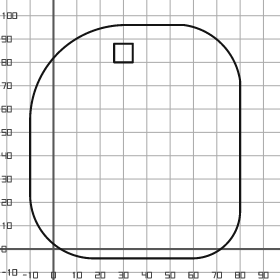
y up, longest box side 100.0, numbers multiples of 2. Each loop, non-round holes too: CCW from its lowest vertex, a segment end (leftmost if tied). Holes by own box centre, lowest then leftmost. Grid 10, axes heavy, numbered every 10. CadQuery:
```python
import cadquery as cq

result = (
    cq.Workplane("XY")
    .moveTo(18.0, -4.0)
    .lineTo(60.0, -4.0)
    .threePointArc((74.0, 2.0), (80.0, 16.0))
    .lineTo(80.0, 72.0)
    .threePointArc((72.0, 88.0), (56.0, 96.0))
    .lineTo(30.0, 96.0)
    .threePointArc((2.0, 84.0), (-10.0, 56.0))
    .lineTo(-10.0, 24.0)
    .threePointArc((-2.0, 4.0), (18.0, -4.0))
    .close()
    .moveTo(26.0, 80.0)
    .lineTo(34.0, 80.0)
    .lineTo(34.0, 88.0)
    .lineTo(26.0, 88.0)
    .close()
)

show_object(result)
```